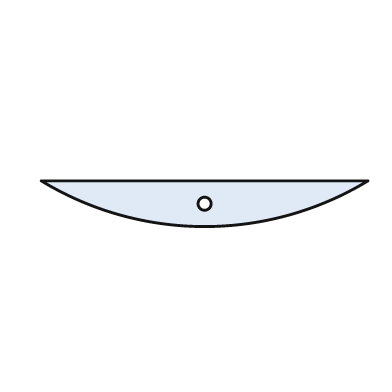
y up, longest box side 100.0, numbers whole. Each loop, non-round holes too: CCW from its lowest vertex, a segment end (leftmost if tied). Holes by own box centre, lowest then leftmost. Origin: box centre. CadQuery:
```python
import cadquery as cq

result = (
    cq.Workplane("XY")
    .moveTo(-50.0, 7.0)
    .threePointArc((0.0, -7.0), (50.0, 7.0))
    .close()
    .moveTo(0.0, 0.0)
    .circle(2.0)
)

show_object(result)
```